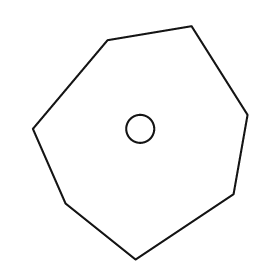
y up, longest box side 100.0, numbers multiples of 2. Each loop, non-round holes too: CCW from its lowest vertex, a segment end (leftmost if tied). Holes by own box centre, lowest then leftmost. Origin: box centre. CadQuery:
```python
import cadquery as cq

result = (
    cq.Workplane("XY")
    .moveTo(-2.0, -50.0)
    .lineTo(40.0, -22.0)
    .lineTo(46.0, 12.0)
    .lineTo(22.0, 50.0)
    .lineTo(-14.0, 44.0)
    .lineTo(-46.0, 6.0)
    .lineTo(-32.0, -26.0)
    .close()
    .moveTo(0.0, 6.0)
    .circle(6.0)
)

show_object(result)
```